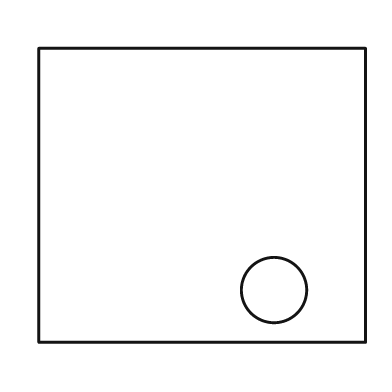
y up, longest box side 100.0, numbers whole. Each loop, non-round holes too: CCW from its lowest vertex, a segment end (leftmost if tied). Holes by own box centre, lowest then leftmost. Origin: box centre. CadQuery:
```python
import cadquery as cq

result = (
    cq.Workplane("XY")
    .moveTo(-50.0, -45.0)
    .lineTo(50.0, -45.0)
    .lineTo(50.0, 45.0)
    .lineTo(-50.0, 45.0)
    .close()
    .moveTo(22.0, -29.0)
    .circle(10.0)
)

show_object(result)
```